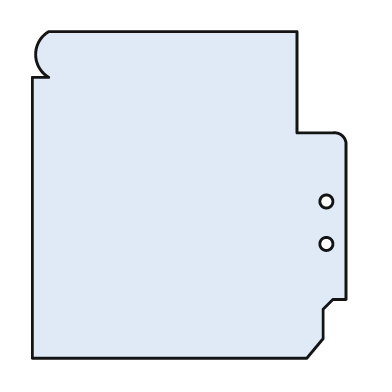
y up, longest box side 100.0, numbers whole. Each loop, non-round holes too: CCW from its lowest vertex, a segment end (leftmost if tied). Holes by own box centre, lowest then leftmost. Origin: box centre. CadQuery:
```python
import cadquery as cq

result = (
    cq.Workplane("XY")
    .moveTo(-48.0, -50.0)
    .lineTo(36.0, -50.0)
    .lineTo(41.0, -44.0)
    .lineTo(41.0, -35.0)
    .lineTo(44.0, -32.0)
    .lineTo(48.0, -32.0)
    .lineTo(48.0, 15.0)
    .threePointArc((47.0, 18.0), (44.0, 19.0))
    .lineTo(33.0, 19.0)
    .lineTo(33.0, 50.0)
    .lineTo(-43.0, 50.0)
    .threePointArc((-47.0, 43.0), (-43.0, 36.0))
    .lineTo(-48.0, 36.0)
    .close()
    .moveTo(42.0, -15.0)
    .circle(2.0)
    .moveTo(42.0, -2.0)
    .circle(2.0)
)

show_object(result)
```